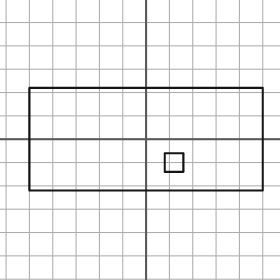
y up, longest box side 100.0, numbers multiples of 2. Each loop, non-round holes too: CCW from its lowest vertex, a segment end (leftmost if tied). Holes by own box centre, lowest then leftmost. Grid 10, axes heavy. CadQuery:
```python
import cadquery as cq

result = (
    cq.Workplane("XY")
    .moveTo(-50.0, -22.0)
    .lineTo(50.0, -22.0)
    .lineTo(50.0, 22.0)
    .lineTo(-50.0, 22.0)
    .close()
    .moveTo(8.0, -14.0)
    .lineTo(16.0, -14.0)
    .lineTo(16.0, -6.0)
    .lineTo(8.0, -6.0)
    .close()
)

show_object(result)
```